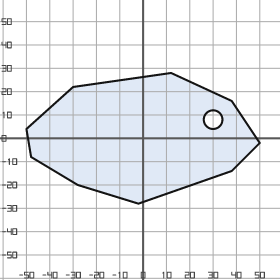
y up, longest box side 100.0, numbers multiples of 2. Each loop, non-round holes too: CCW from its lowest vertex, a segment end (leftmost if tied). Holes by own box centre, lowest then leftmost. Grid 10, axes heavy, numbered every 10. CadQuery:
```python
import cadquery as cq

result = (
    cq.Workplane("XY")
    .moveTo(-2.0, -28.0)
    .lineTo(38.0, -14.0)
    .lineTo(50.0, -2.0)
    .lineTo(38.0, 16.0)
    .lineTo(12.0, 28.0)
    .lineTo(-30.0, 22.0)
    .lineTo(-50.0, 4.0)
    .lineTo(-48.0, -8.0)
    .lineTo(-28.0, -20.0)
    .close()
    .moveTo(30.0, 8.0)
    .circle(4.0)
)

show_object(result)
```